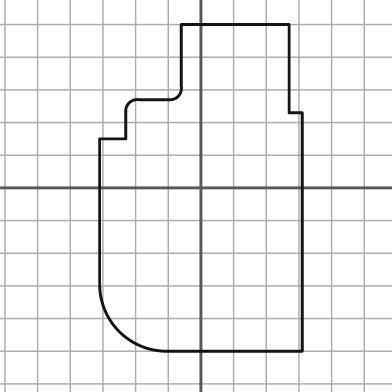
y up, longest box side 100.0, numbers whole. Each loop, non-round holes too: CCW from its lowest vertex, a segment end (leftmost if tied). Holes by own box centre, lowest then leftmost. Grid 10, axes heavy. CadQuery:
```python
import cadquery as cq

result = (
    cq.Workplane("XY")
    .moveTo(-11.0, -50.0)
    .lineTo(31.0, -50.0)
    .lineTo(31.0, 23.0)
    .lineTo(27.0, 23.0)
    .lineTo(27.0, 50.0)
    .lineTo(-6.0, 50.0)
    .lineTo(-6.0, 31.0)
    .threePointArc((-7.0, 28.0), (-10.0, 27.0))
    .lineTo(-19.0, 27.0)
    .threePointArc((-22.0, 26.0), (-23.0, 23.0))
    .lineTo(-23.0, 15.0)
    .lineTo(-31.0, 15.0)
    .lineTo(-31.0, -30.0)
    .threePointArc((-25.0, -44.0), (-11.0, -50.0))
    .close()
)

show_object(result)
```